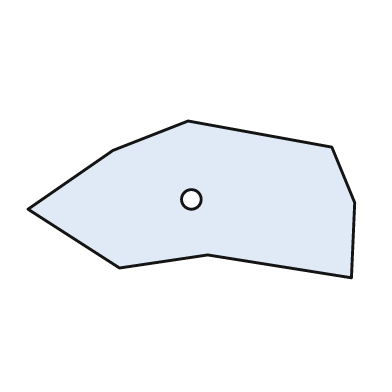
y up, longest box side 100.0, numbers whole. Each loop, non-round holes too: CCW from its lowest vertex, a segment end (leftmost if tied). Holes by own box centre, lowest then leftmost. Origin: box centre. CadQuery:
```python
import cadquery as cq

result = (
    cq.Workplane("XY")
    .moveTo(49.0, -24.0)
    .lineTo(50.0, -1.0)
    .lineTo(43.0, 16.0)
    .lineTo(-1.0, 24.0)
    .lineTo(-24.0, 15.0)
    .lineTo(-50.0, -3.0)
    .lineTo(-22.0, -21.0)
    .lineTo(5.0, -17.0)
    .close()
    .moveTo(0.0, 0.0)
    .circle(3.0)
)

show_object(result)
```